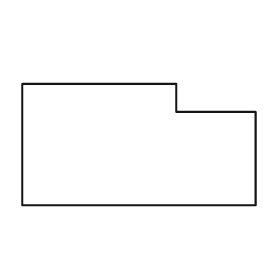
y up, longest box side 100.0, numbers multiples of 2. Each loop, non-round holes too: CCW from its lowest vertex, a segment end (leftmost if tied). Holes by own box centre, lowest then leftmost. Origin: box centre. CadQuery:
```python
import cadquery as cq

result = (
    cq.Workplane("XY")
    .moveTo(-50.0, -26.0)
    .lineTo(50.0, -26.0)
    .lineTo(50.0, 14.0)
    .lineTo(16.0, 14.0)
    .lineTo(16.0, 26.0)
    .lineTo(-50.0, 26.0)
    .close()
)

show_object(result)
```